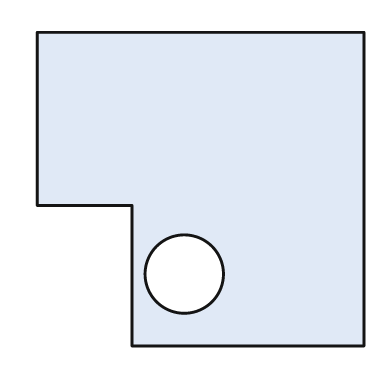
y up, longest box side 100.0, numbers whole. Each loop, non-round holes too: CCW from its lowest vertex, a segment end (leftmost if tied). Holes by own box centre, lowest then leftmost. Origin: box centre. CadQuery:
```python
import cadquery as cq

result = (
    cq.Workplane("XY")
    .moveTo(-21.0, -48.0)
    .lineTo(50.0, -48.0)
    .lineTo(50.0, 48.0)
    .lineTo(-50.0, 48.0)
    .lineTo(-50.0, -5.0)
    .lineTo(-21.0, -5.0)
    .close()
    .moveTo(-5.0, -26.0)
    .circle(12.0)
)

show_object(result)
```